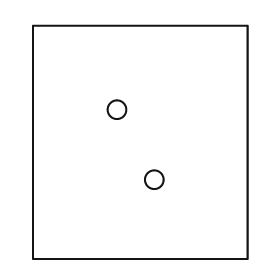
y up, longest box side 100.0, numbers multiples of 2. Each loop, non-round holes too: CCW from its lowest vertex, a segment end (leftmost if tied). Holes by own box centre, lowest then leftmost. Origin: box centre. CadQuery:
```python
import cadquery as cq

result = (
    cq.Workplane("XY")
    .moveTo(-46.0, -50.0)
    .lineTo(46.0, -50.0)
    .lineTo(46.0, 50.0)
    .lineTo(-46.0, 50.0)
    .close()
    .moveTo(6.0, -16.0)
    .circle(4.0)
    .moveTo(-10.0, 14.0)
    .circle(4.0)
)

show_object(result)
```